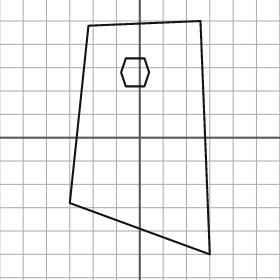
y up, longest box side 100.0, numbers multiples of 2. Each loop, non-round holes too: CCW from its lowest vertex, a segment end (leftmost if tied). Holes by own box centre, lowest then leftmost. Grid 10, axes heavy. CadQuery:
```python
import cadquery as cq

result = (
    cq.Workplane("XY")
    .moveTo(30.0, -50.0)
    .lineTo(26.0, 50.0)
    .lineTo(-22.0, 48.0)
    .lineTo(-30.0, -28.0)
    .close()
    .moveTo(-6.0, 22.0)
    .lineTo(2.0, 22.0)
    .lineTo(4.0, 28.0)
    .lineTo(2.0, 34.0)
    .lineTo(-6.0, 34.0)
    .lineTo(-8.0, 28.0)
    .close()
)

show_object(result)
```